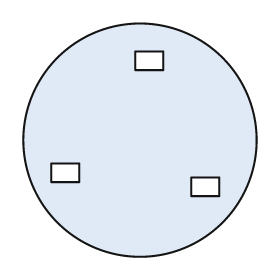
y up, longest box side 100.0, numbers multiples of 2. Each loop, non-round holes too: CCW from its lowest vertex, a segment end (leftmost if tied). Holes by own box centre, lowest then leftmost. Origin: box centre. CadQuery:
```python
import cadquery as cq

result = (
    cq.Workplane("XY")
    .moveTo(0.0, 0.0)
    .circle(50.0)
    .moveTo(22.0, -24.0)
    .lineTo(34.0, -24.0)
    .lineTo(34.0, -16.0)
    .lineTo(22.0, -16.0)
    .close()
    .moveTo(-38.0, -18.0)
    .lineTo(-26.0, -18.0)
    .lineTo(-26.0, -10.0)
    .lineTo(-38.0, -10.0)
    .close()
    .moveTo(-2.0, 30.0)
    .lineTo(10.0, 30.0)
    .lineTo(10.0, 38.0)
    .lineTo(-2.0, 38.0)
    .close()
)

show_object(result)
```